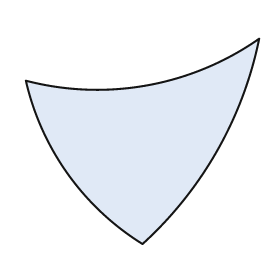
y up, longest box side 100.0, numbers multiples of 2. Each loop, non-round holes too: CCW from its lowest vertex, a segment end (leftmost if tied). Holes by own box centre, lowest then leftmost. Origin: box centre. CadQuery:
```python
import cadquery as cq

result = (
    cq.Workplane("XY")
    .moveTo(0.0, -44.0)
    .threePointArc((32.0, -4.0), (50.0, 44.0))
    .threePointArc((2.0, 24.0), (-50.0, 26.0))
    .threePointArc((-32.0, -14.0), (0.0, -44.0))
    .close()
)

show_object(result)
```